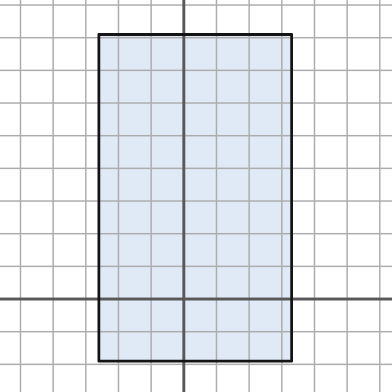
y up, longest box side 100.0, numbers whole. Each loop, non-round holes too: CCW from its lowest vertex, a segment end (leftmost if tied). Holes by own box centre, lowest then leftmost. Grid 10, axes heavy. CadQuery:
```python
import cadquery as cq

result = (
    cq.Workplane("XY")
    .moveTo(-26.0, -19.0)
    .lineTo(33.0, -19.0)
    .lineTo(33.0, 81.0)
    .lineTo(-26.0, 81.0)
    .close()
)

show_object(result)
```